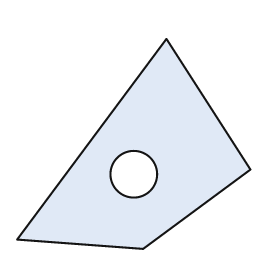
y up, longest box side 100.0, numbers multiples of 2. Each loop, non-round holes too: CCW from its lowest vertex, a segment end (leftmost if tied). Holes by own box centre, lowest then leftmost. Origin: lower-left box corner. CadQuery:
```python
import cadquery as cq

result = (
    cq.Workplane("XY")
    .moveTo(54.0, 0.0)
    .lineTo(100.0, 34.0)
    .lineTo(64.0, 90.0)
    .lineTo(0.0, 4.0)
    .close()
    .moveTo(50.0, 32.0)
    .circle(10.0)
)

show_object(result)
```